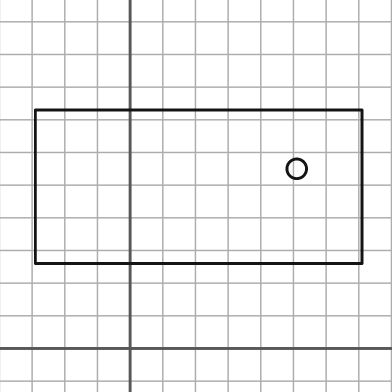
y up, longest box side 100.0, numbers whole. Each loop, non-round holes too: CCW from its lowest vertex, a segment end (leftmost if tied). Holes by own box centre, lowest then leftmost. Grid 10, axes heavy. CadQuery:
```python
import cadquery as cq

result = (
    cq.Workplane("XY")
    .moveTo(-29.0, 26.0)
    .lineTo(71.0, 26.0)
    .lineTo(71.0, 73.0)
    .lineTo(-29.0, 73.0)
    .close()
    .moveTo(51.0, 55.0)
    .circle(3.0)
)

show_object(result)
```